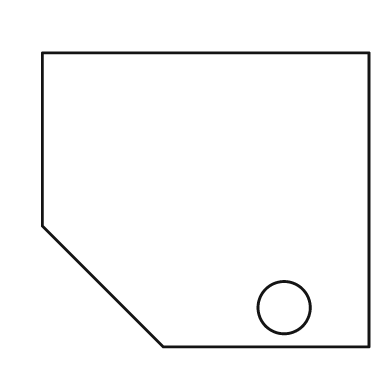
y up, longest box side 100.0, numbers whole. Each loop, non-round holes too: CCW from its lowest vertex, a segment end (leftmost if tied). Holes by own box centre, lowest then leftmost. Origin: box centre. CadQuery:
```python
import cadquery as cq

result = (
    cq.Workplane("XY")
    .moveTo(-13.0, -45.0)
    .lineTo(50.0, -45.0)
    .lineTo(50.0, 45.0)
    .lineTo(-50.0, 45.0)
    .lineTo(-50.0, -8.0)
    .close()
    .moveTo(24.0, -33.0)
    .circle(8.0)
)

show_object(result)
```